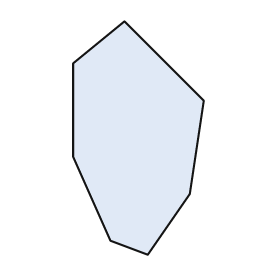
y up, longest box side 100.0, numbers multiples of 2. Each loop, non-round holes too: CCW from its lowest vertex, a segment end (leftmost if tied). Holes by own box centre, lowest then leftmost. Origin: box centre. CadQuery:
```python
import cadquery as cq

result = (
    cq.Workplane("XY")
    .moveTo(4.0, -50.0)
    .lineTo(22.0, -24.0)
    .lineTo(28.0, 16.0)
    .lineTo(-6.0, 50.0)
    .lineTo(-28.0, 32.0)
    .lineTo(-28.0, -8.0)
    .lineTo(-12.0, -44.0)
    .close()
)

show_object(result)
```